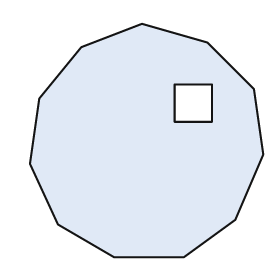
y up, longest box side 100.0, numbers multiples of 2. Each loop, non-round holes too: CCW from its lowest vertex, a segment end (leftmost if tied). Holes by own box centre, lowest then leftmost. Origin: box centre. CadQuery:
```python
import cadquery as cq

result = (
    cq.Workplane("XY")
    .moveTo(-14.0, -50.0)
    .lineTo(16.0, -50.0)
    .lineTo(38.0, -34.0)
    .lineTo(50.0, -6.0)
    .lineTo(46.0, 22.0)
    .lineTo(26.0, 42.0)
    .lineTo(-2.0, 50.0)
    .lineTo(-28.0, 40.0)
    .lineTo(-46.0, 18.0)
    .lineTo(-50.0, -10.0)
    .lineTo(-38.0, -36.0)
    .close()
    .moveTo(12.0, 8.0)
    .lineTo(28.0, 8.0)
    .lineTo(28.0, 24.0)
    .lineTo(12.0, 24.0)
    .close()
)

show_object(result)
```